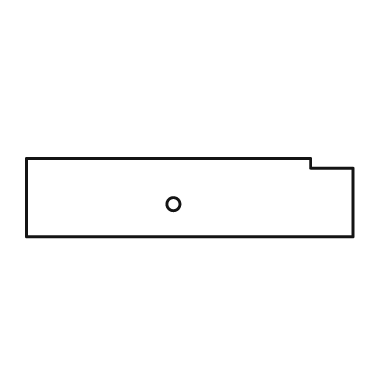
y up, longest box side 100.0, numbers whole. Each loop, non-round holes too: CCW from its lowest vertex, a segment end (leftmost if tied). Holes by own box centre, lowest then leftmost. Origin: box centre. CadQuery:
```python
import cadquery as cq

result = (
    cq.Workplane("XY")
    .moveTo(-50.0, -12.0)
    .lineTo(50.0, -12.0)
    .lineTo(50.0, 9.0)
    .lineTo(37.0, 9.0)
    .lineTo(37.0, 12.0)
    .lineTo(-50.0, 12.0)
    .close()
    .moveTo(-5.0, -2.0)
    .circle(2.0)
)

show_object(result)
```